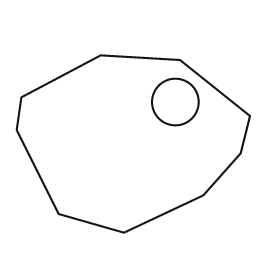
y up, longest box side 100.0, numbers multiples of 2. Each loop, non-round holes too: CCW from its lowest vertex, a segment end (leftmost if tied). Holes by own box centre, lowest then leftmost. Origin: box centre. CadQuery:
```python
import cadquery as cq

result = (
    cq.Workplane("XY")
    .moveTo(-4.0, -38.0)
    .lineTo(30.0, -22.0)
    .lineTo(46.0, -4.0)
    .lineTo(50.0, 12.0)
    .lineTo(20.0, 36.0)
    .lineTo(-14.0, 38.0)
    .lineTo(-48.0, 20.0)
    .lineTo(-50.0, 6.0)
    .lineTo(-32.0, -30.0)
    .close()
    .moveTo(18.0, 18.0)
    .circle(10.0)
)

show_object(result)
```